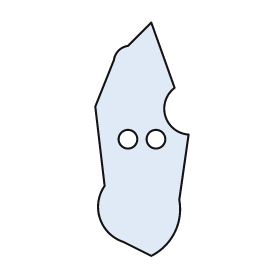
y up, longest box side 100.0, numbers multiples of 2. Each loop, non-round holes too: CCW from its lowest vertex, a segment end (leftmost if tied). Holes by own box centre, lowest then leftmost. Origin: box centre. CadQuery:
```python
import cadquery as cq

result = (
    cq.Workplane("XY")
    .moveTo(4.0, -50.0)
    .threePointArc((14.0, -40.0), (16.0, -26.0))
    .lineTo(20.0, 2.0)
    .threePointArc((10.0, 10.0), (14.0, 22.0))
    .lineTo(4.0, 50.0)
    .lineTo(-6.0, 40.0)
    .threePointArc((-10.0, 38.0), (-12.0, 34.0))
    .lineTo(-20.0, 14.0)
    .lineTo(-16.0, -20.0)
    .threePointArc((-18.0, -34.0), (-8.0, -44.0))
    .close()
    .moveTo(-6.0, 0.0)
    .circle(4.0)
    .moveTo(6.0, 0.0)
    .circle(4.0)
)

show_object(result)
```